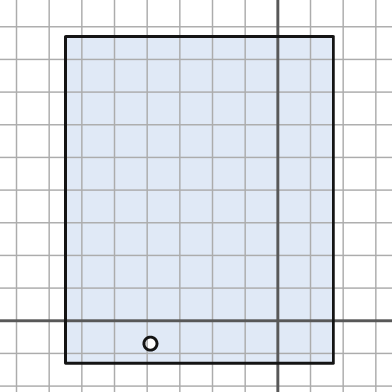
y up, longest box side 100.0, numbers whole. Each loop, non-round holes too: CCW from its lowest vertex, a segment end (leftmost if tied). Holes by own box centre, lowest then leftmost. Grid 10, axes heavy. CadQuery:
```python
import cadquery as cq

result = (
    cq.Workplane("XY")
    .moveTo(-65.0, -13.0)
    .lineTo(17.0, -13.0)
    .lineTo(17.0, 87.0)
    .lineTo(-65.0, 87.0)
    .close()
    .moveTo(-39.0, -7.0)
    .circle(2.0)
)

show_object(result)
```